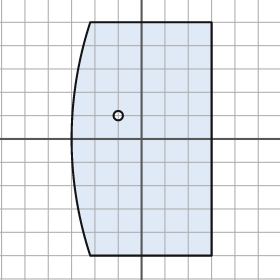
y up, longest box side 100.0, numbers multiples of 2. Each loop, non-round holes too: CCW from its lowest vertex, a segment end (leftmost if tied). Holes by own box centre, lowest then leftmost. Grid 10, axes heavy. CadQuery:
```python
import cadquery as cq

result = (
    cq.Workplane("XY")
    .moveTo(-22.0, -50.0)
    .lineTo(30.0, -50.0)
    .lineTo(30.0, 50.0)
    .lineTo(-22.0, 50.0)
    .threePointArc((-30.0, 0.0), (-22.0, -50.0))
    .close()
    .moveTo(-10.0, 10.0)
    .circle(2.0)
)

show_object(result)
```